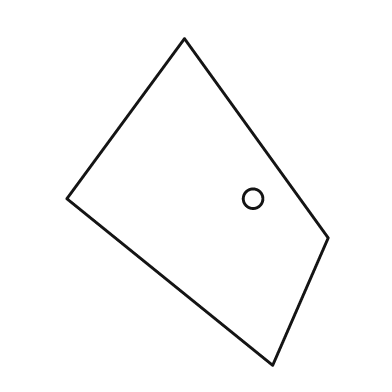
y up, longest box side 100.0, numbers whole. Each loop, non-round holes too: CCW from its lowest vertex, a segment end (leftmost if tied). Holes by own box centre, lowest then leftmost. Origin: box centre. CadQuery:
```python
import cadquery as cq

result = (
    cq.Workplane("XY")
    .moveTo(23.0, -50.0)
    .lineTo(40.0, -11.0)
    .lineTo(-4.0, 50.0)
    .lineTo(-40.0, 1.0)
    .close()
    .moveTo(17.0, 1.0)
    .circle(3.0)
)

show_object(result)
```